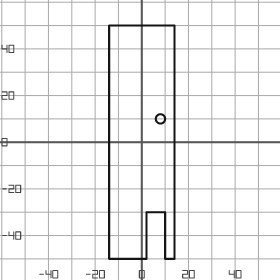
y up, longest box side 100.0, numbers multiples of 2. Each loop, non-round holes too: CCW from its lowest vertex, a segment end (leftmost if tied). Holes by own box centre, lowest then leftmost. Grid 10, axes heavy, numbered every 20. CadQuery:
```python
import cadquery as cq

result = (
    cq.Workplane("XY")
    .moveTo(-14.0, -50.0)
    .lineTo(2.0, -50.0)
    .lineTo(2.0, -30.0)
    .lineTo(10.0, -30.0)
    .lineTo(10.0, -50.0)
    .lineTo(14.0, -50.0)
    .lineTo(14.0, 50.0)
    .lineTo(-14.0, 50.0)
    .close()
    .moveTo(8.0, 10.0)
    .circle(2.0)
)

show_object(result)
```